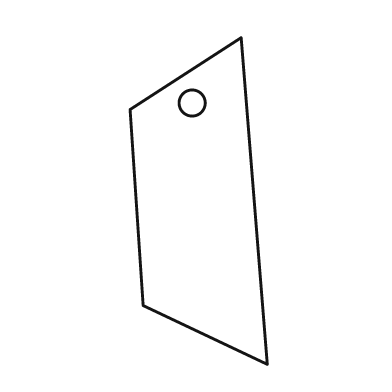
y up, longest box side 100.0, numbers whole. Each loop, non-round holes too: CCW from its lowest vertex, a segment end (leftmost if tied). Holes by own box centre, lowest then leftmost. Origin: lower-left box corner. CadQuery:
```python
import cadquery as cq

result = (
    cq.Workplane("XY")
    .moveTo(42.0, 0.0)
    .lineTo(34.0, 100.0)
    .lineTo(0.0, 78.0)
    .lineTo(4.0, 18.0)
    .close()
    .moveTo(19.0, 80.0)
    .circle(4.0)
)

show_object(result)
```